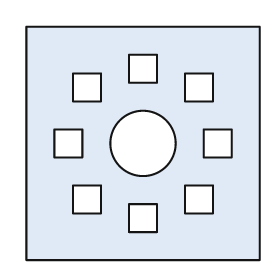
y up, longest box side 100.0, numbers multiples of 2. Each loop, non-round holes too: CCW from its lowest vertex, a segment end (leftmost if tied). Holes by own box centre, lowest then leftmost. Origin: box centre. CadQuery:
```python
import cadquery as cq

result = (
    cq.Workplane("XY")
    .moveTo(-50.0, -50.0)
    .lineTo(50.0, -50.0)
    .lineTo(50.0, 50.0)
    .lineTo(-50.0, 50.0)
    .close()
    .moveTo(-6.0, -38.0)
    .lineTo(6.0, -38.0)
    .lineTo(6.0, -26.0)
    .lineTo(-6.0, -26.0)
    .close()
    .moveTo(-30.0, -30.0)
    .lineTo(-18.0, -30.0)
    .lineTo(-18.0, -18.0)
    .lineTo(-30.0, -18.0)
    .close()
    .moveTo(18.0, -30.0)
    .lineTo(30.0, -30.0)
    .lineTo(30.0, -18.0)
    .lineTo(18.0, -18.0)
    .close()
    .moveTo(-38.0, -6.0)
    .lineTo(-26.0, -6.0)
    .lineTo(-26.0, 6.0)
    .lineTo(-38.0, 6.0)
    .close()
    .moveTo(0.0, 0.0)
    .circle(14.0)
    .moveTo(26.0, -6.0)
    .lineTo(38.0, -6.0)
    .lineTo(38.0, 6.0)
    .lineTo(26.0, 6.0)
    .close()
    .moveTo(-30.0, 18.0)
    .lineTo(-18.0, 18.0)
    .lineTo(-18.0, 30.0)
    .lineTo(-30.0, 30.0)
    .close()
    .moveTo(18.0, 18.0)
    .lineTo(30.0, 18.0)
    .lineTo(30.0, 30.0)
    .lineTo(18.0, 30.0)
    .close()
    .moveTo(-6.0, 26.0)
    .lineTo(6.0, 26.0)
    .lineTo(6.0, 38.0)
    .lineTo(-6.0, 38.0)
    .close()
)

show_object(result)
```